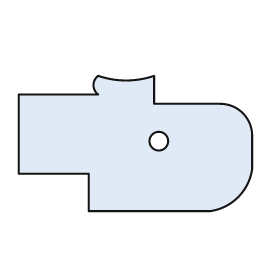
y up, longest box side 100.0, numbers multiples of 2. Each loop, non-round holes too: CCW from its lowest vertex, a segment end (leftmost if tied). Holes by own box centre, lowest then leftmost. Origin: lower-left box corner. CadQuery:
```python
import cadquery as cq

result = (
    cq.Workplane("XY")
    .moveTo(30.0, 0.0)
    .lineTo(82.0, 0.0)
    .threePointArc((94.0, 6.0), (100.0, 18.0))
    .lineTo(100.0, 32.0)
    .threePointArc((96.0, 42.0), (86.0, 46.0))
    .lineTo(58.0, 46.0)
    .lineTo(58.0, 58.0)
    .threePointArc((46.0, 56.0), (34.0, 58.0))
    .threePointArc((32.0, 54.0), (34.0, 50.0))
    .lineTo(0.0, 50.0)
    .lineTo(0.0, 16.0)
    .lineTo(30.0, 16.0)
    .close()
    .moveTo(60.0, 30.0)
    .circle(4.0)
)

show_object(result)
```